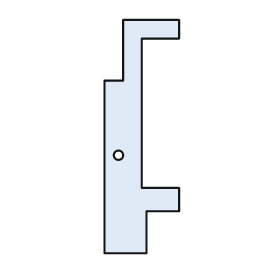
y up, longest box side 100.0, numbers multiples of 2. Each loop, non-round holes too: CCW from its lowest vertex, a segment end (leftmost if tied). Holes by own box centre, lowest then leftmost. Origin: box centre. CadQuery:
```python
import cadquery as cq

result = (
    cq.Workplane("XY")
    .moveTo(-16.0, -50.0)
    .lineTo(2.0, -50.0)
    .lineTo(2.0, -32.0)
    .lineTo(16.0, -32.0)
    .lineTo(16.0, -22.0)
    .lineTo(0.0, -22.0)
    .lineTo(0.0, 42.0)
    .lineTo(16.0, 42.0)
    .lineTo(16.0, 50.0)
    .lineTo(-8.0, 50.0)
    .lineTo(-8.0, 24.0)
    .lineTo(-16.0, 24.0)
    .close()
    .moveTo(-10.0, -8.0)
    .circle(2.0)
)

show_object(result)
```